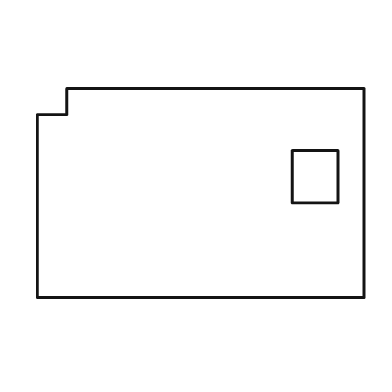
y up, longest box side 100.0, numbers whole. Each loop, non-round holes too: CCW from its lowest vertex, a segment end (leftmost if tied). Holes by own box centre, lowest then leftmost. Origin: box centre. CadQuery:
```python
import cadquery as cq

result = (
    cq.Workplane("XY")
    .moveTo(-50.0, -32.0)
    .lineTo(50.0, -32.0)
    .lineTo(50.0, 32.0)
    .lineTo(-41.0, 32.0)
    .lineTo(-41.0, 24.0)
    .lineTo(-50.0, 24.0)
    .close()
    .moveTo(28.0, -3.0)
    .lineTo(42.0, -3.0)
    .lineTo(42.0, 13.0)
    .lineTo(28.0, 13.0)
    .close()
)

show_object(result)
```